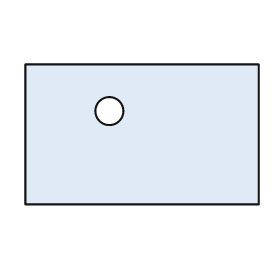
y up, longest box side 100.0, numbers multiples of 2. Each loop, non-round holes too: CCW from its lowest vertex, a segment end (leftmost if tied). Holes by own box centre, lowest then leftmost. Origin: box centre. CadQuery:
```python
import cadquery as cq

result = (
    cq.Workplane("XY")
    .moveTo(-50.0, -30.0)
    .lineTo(50.0, -30.0)
    .lineTo(50.0, 30.0)
    .lineTo(-50.0, 30.0)
    .close()
    .moveTo(-14.0, 10.0)
    .circle(6.0)
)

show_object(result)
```